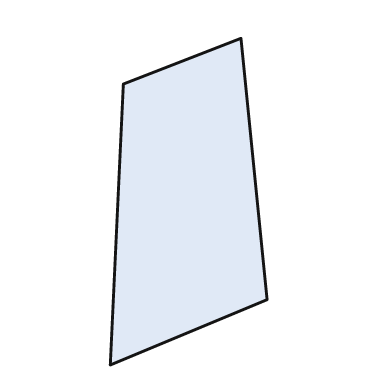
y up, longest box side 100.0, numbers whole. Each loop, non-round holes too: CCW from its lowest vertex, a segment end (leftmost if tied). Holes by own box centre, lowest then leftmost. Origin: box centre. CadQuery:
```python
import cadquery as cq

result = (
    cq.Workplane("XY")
    .moveTo(-24.0, -50.0)
    .lineTo(24.0, -30.0)
    .lineTo(16.0, 50.0)
    .lineTo(-20.0, 36.0)
    .close()
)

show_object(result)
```